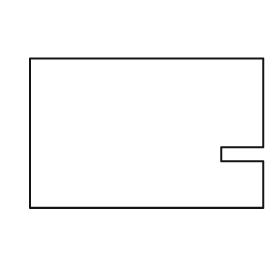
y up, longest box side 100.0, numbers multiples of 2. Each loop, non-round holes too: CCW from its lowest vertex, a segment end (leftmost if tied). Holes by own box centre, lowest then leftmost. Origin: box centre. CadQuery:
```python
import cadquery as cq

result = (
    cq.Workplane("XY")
    .moveTo(-50.0, -32.0)
    .lineTo(50.0, -32.0)
    .lineTo(50.0, -12.0)
    .lineTo(32.0, -12.0)
    .lineTo(32.0, -6.0)
    .lineTo(50.0, -6.0)
    .lineTo(50.0, 32.0)
    .lineTo(-50.0, 32.0)
    .close()
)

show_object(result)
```